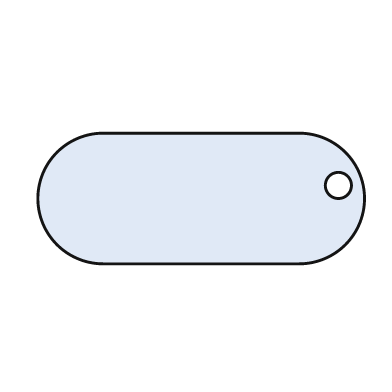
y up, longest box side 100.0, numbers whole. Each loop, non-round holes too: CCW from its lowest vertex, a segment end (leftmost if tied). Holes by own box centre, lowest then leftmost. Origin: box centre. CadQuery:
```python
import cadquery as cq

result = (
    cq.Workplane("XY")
    .moveTo(-30.0, -20.0)
    .lineTo(30.0, -20.0)
    .threePointArc((50.0, 0.0), (30.0, 20.0))
    .lineTo(-30.0, 20.0)
    .threePointArc((-50.0, 0.0), (-30.0, -20.0))
    .close()
    .moveTo(42.0, 4.0)
    .circle(4.0)
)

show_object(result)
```